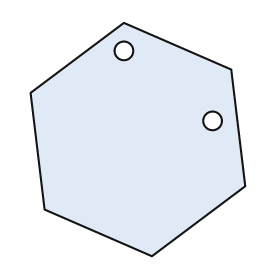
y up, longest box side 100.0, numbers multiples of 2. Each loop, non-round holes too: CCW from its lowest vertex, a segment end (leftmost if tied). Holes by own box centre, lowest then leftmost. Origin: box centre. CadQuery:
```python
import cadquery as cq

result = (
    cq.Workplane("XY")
    .moveTo(6.0, -50.0)
    .lineTo(46.0, -20.0)
    .lineTo(40.0, 30.0)
    .lineTo(-6.0, 50.0)
    .lineTo(-46.0, 20.0)
    .lineTo(-40.0, -30.0)
    .close()
    .moveTo(32.0, 8.0)
    .circle(4.0)
    .moveTo(-6.0, 38.0)
    .circle(4.0)
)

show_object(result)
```